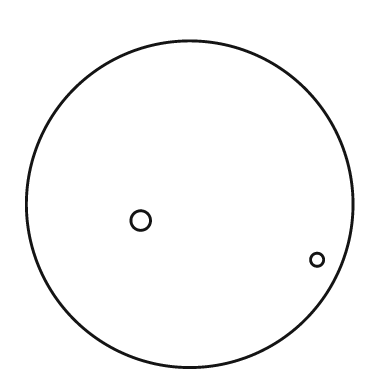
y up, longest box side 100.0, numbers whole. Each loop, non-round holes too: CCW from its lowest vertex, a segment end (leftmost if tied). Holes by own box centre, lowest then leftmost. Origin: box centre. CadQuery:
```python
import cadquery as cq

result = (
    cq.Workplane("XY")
    .moveTo(0.0, 0.0)
    .circle(50.0)
    .moveTo(39.0, -17.0)
    .circle(2.0)
    .moveTo(-15.0, -5.0)
    .circle(3.0)
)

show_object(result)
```